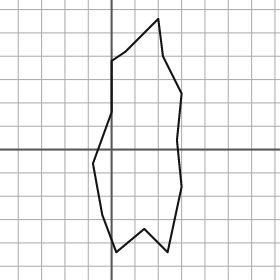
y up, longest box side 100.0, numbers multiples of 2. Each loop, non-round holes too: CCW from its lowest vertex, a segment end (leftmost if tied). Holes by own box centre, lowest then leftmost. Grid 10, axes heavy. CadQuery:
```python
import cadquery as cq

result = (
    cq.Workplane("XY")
    .moveTo(2.0, -44.0)
    .lineTo(14.0, -34.0)
    .lineTo(24.0, -44.0)
    .lineTo(30.0, -16.0)
    .lineTo(28.0, 4.0)
    .lineTo(30.0, 24.0)
    .lineTo(22.0, 40.0)
    .lineTo(20.0, 56.0)
    .lineTo(6.0, 42.0)
    .lineTo(0.0, 38.0)
    .lineTo(0.0, 16.0)
    .lineTo(-8.0, -6.0)
    .lineTo(-4.0, -28.0)
    .close()
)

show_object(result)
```